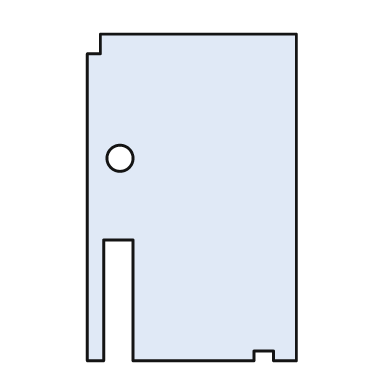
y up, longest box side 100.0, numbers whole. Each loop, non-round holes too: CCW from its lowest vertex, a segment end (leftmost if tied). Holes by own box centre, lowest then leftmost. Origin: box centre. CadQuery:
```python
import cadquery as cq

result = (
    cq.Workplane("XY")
    .moveTo(-32.0, -50.0)
    .lineTo(-27.0, -50.0)
    .lineTo(-27.0, -13.0)
    .lineTo(-18.0, -13.0)
    .lineTo(-18.0, -50.0)
    .lineTo(19.0, -50.0)
    .lineTo(19.0, -47.0)
    .lineTo(25.0, -47.0)
    .lineTo(25.0, -50.0)
    .lineTo(32.0, -50.0)
    .lineTo(32.0, 50.0)
    .lineTo(-28.0, 50.0)
    .lineTo(-28.0, 44.0)
    .lineTo(-32.0, 44.0)
    .close()
    .moveTo(-22.0, 12.0)
    .circle(4.0)
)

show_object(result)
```